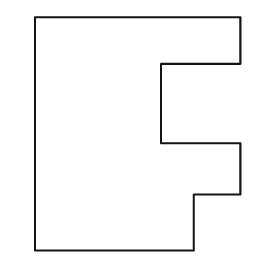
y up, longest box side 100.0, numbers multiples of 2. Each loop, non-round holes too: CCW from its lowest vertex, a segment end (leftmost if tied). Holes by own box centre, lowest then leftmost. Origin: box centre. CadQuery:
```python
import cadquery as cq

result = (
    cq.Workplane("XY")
    .moveTo(-44.0, -50.0)
    .lineTo(24.0, -50.0)
    .lineTo(24.0, -26.0)
    .lineTo(44.0, -26.0)
    .lineTo(44.0, -4.0)
    .lineTo(10.0, -4.0)
    .lineTo(10.0, 30.0)
    .lineTo(44.0, 30.0)
    .lineTo(44.0, 50.0)
    .lineTo(-44.0, 50.0)
    .close()
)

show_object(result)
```